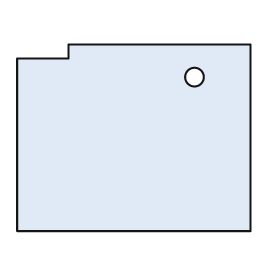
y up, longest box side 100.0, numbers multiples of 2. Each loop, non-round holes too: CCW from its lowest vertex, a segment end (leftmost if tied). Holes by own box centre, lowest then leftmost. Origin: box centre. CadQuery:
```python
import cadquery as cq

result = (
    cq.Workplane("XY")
    .moveTo(-50.0, -40.0)
    .lineTo(50.0, -40.0)
    .lineTo(50.0, 40.0)
    .lineTo(-28.0, 40.0)
    .lineTo(-28.0, 34.0)
    .lineTo(-50.0, 34.0)
    .close()
    .moveTo(26.0, 26.0)
    .circle(4.0)
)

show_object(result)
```